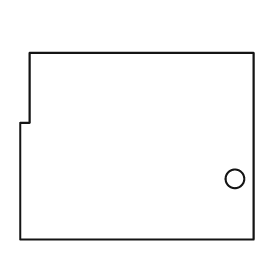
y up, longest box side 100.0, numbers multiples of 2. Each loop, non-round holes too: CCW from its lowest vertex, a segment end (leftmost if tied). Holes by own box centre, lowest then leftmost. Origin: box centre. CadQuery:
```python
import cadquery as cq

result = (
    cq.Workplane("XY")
    .moveTo(-50.0, -40.0)
    .lineTo(50.0, -40.0)
    .lineTo(50.0, 40.0)
    .lineTo(-46.0, 40.0)
    .lineTo(-46.0, 10.0)
    .lineTo(-50.0, 10.0)
    .close()
    .moveTo(42.0, -14.0)
    .circle(4.0)
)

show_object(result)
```